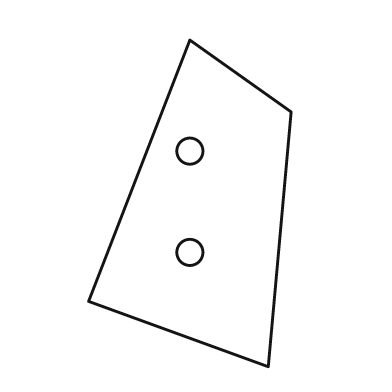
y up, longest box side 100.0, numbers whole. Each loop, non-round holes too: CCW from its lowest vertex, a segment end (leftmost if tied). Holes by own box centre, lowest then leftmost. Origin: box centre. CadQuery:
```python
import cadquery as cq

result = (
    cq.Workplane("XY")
    .moveTo(24.0, -50.0)
    .lineTo(31.0, 28.0)
    .lineTo(0.0, 50.0)
    .lineTo(-31.0, -30.0)
    .close()
    .moveTo(0.0, -15.0)
    .circle(4.0)
    .moveTo(0.0, 16.0)
    .circle(4.0)
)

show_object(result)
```